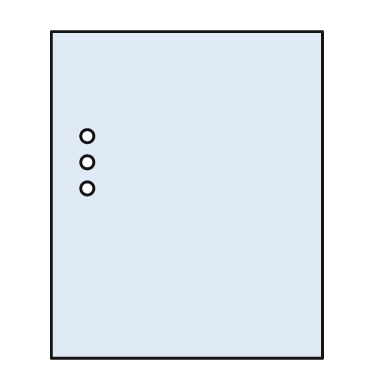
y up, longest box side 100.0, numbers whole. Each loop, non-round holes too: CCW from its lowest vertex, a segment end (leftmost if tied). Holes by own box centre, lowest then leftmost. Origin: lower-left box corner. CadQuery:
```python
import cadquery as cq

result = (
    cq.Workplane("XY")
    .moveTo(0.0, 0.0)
    .lineTo(83.0, 0.0)
    .lineTo(83.0, 100.0)
    .lineTo(0.0, 100.0)
    .close()
    .moveTo(11.0, 52.0)
    .circle(2.0)
    .moveTo(11.0, 60.0)
    .circle(2.0)
    .moveTo(11.0, 68.0)
    .circle(2.0)
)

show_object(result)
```